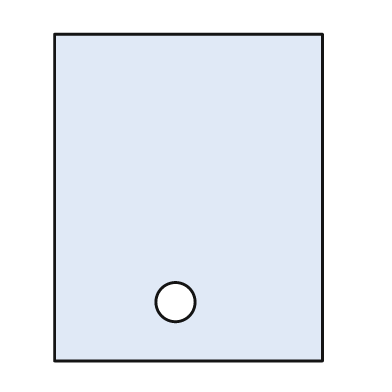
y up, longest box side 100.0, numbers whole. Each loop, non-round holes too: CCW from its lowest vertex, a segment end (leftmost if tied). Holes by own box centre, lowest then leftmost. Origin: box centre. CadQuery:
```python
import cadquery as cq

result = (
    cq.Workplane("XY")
    .moveTo(-41.0, -50.0)
    .lineTo(41.0, -50.0)
    .lineTo(41.0, 50.0)
    .lineTo(-41.0, 50.0)
    .close()
    .moveTo(-4.0, -32.0)
    .circle(6.0)
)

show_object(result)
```